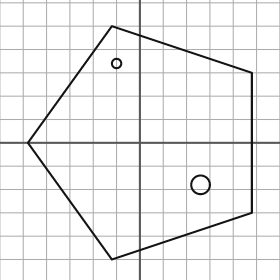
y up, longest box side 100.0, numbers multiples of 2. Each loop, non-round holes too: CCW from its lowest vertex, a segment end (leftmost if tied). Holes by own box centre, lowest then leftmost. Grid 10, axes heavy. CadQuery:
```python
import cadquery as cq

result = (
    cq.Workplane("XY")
    .moveTo(-12.0, -50.0)
    .lineTo(48.0, -30.0)
    .lineTo(48.0, 30.0)
    .lineTo(-12.0, 50.0)
    .lineTo(-48.0, 0.0)
    .close()
    .moveTo(26.0, -18.0)
    .circle(4.0)
    .moveTo(-10.0, 34.0)
    .circle(2.0)
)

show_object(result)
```